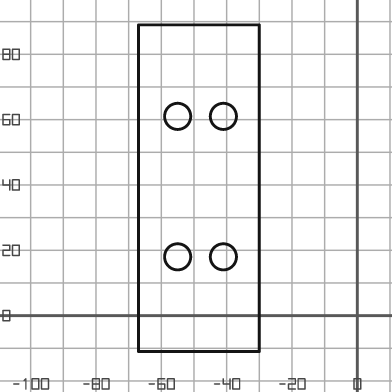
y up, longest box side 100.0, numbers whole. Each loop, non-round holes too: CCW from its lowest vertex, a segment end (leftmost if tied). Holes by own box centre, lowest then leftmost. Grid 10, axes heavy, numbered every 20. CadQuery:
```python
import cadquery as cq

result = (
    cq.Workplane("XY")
    .moveTo(-67.0, -11.0)
    .lineTo(-30.0, -11.0)
    .lineTo(-30.0, 89.0)
    .lineTo(-67.0, 89.0)
    .close()
    .moveTo(-55.0, 18.0)
    .circle(4.0)
    .moveTo(-41.0, 18.0)
    .circle(4.0)
    .moveTo(-55.0, 61.0)
    .circle(4.0)
    .moveTo(-41.0, 61.0)
    .circle(4.0)
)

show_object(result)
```